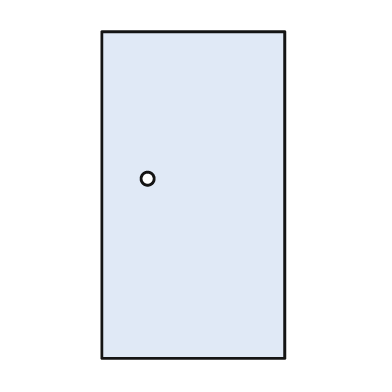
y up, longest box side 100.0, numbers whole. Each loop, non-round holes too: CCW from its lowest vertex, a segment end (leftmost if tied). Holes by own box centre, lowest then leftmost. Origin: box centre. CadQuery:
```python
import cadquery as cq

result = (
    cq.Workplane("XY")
    .moveTo(-28.0, -50.0)
    .lineTo(28.0, -50.0)
    .lineTo(28.0, 50.0)
    .lineTo(-28.0, 50.0)
    .close()
    .moveTo(-14.0, 5.0)
    .circle(2.0)
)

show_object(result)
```